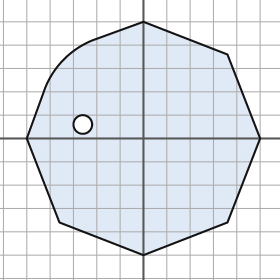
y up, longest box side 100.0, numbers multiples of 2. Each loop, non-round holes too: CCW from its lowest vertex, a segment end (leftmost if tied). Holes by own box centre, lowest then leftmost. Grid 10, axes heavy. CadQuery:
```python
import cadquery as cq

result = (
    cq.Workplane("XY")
    .moveTo(0.0, -50.0)
    .lineTo(36.0, -36.0)
    .lineTo(50.0, 0.0)
    .lineTo(36.0, 36.0)
    .lineTo(0.0, 50.0)
    .lineTo(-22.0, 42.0)
    .threePointArc((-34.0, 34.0), (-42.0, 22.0))
    .lineTo(-50.0, 0.0)
    .lineTo(-36.0, -36.0)
    .close()
    .moveTo(-26.0, 6.0)
    .circle(4.0)
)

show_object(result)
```